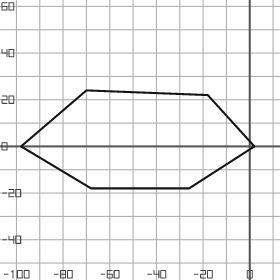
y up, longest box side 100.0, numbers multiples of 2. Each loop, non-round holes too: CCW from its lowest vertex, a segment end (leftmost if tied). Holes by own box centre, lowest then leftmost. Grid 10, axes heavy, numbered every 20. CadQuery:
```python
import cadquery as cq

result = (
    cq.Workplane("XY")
    .moveTo(-68.0, -18.0)
    .lineTo(-26.0, -18.0)
    .lineTo(2.0, 0.0)
    .lineTo(-18.0, 22.0)
    .lineTo(-70.0, 24.0)
    .lineTo(-98.0, 0.0)
    .close()
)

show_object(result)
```